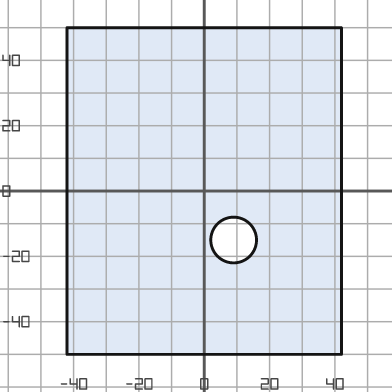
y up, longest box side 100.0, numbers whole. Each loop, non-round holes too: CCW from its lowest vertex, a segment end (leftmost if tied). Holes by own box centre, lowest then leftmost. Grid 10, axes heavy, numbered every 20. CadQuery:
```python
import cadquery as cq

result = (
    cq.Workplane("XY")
    .moveTo(-42.0, -50.0)
    .lineTo(42.0, -50.0)
    .lineTo(42.0, 50.0)
    .lineTo(-42.0, 50.0)
    .close()
    .moveTo(9.0, -15.0)
    .circle(7.0)
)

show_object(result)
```